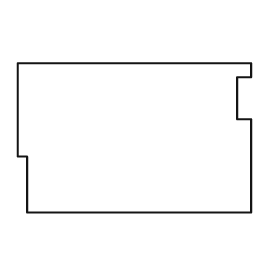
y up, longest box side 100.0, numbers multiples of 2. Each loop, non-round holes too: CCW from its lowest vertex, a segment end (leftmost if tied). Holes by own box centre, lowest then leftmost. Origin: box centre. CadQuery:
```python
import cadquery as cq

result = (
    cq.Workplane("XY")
    .moveTo(-46.0, -32.0)
    .lineTo(50.0, -32.0)
    .lineTo(50.0, 8.0)
    .lineTo(44.0, 8.0)
    .lineTo(44.0, 26.0)
    .lineTo(50.0, 26.0)
    .lineTo(50.0, 32.0)
    .lineTo(-50.0, 32.0)
    .lineTo(-50.0, -8.0)
    .lineTo(-46.0, -8.0)
    .close()
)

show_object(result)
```